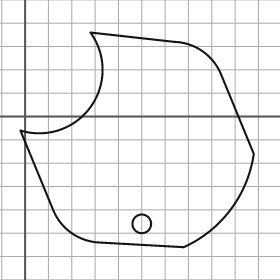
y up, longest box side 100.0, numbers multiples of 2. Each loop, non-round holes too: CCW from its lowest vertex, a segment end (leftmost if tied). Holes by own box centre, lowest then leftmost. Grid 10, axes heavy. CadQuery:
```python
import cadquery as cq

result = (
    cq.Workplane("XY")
    .moveTo(68.0, -56.0)
    .threePointArc((88.0, -40.0), (98.0, -16.0))
    .lineTo(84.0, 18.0)
    .threePointArc((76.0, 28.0), (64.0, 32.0))
    .lineTo(28.0, 36.0)
    .threePointArc((28.0, 4.0), (-2.0, -6.0))
    .lineTo(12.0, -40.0)
    .threePointArc((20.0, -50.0), (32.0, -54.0))
    .close()
    .moveTo(50.0, -46.0)
    .circle(4.0)
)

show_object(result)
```